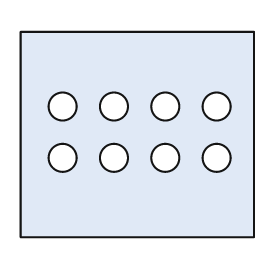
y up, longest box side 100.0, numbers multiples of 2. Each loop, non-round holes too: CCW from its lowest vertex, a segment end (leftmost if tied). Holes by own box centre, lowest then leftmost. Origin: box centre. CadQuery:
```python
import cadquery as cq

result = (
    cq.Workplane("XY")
    .moveTo(-50.0, -44.0)
    .lineTo(50.0, -44.0)
    .lineTo(50.0, 44.0)
    .lineTo(-50.0, 44.0)
    .close()
    .moveTo(-32.0, -10.0)
    .circle(6.0)
    .moveTo(-10.0, -10.0)
    .circle(6.0)
    .moveTo(12.0, -10.0)
    .circle(6.0)
    .moveTo(34.0, -10.0)
    .circle(6.0)
    .moveTo(-32.0, 12.0)
    .circle(6.0)
    .moveTo(-10.0, 12.0)
    .circle(6.0)
    .moveTo(12.0, 12.0)
    .circle(6.0)
    .moveTo(34.0, 12.0)
    .circle(6.0)
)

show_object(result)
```